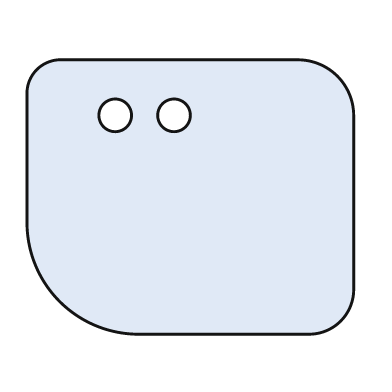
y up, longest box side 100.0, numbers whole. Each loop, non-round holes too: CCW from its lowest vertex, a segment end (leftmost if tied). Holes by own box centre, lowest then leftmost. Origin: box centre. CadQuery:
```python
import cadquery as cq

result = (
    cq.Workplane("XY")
    .moveTo(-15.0, -42.0)
    .lineTo(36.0, -42.0)
    .threePointArc((46.0, -38.0), (50.0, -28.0))
    .lineTo(50.0, 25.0)
    .threePointArc((45.0, 37.0), (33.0, 42.0))
    .lineTo(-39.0, 42.0)
    .threePointArc((-47.0, 39.0), (-50.0, 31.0))
    .lineTo(-50.0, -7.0)
    .threePointArc((-40.0, -32.0), (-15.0, -42.0))
    .close()
    .moveTo(-23.0, 25.0)
    .circle(5.0)
    .moveTo(-5.0, 25.0)
    .circle(5.0)
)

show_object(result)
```